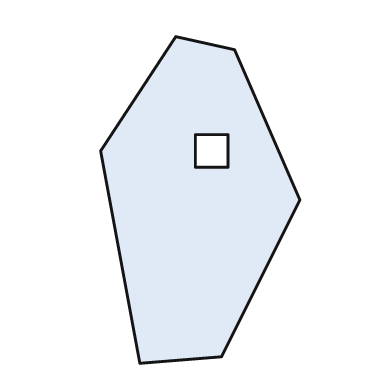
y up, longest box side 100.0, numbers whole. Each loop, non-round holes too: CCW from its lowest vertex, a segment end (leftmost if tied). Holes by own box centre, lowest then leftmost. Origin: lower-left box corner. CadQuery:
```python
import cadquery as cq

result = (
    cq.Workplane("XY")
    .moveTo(12.0, 0.0)
    .lineTo(37.0, 2.0)
    .lineTo(61.0, 50.0)
    .lineTo(41.0, 96.0)
    .lineTo(23.0, 100.0)
    .lineTo(0.0, 65.0)
    .close()
    .moveTo(29.0, 60.0)
    .lineTo(39.0, 60.0)
    .lineTo(39.0, 70.0)
    .lineTo(29.0, 70.0)
    .close()
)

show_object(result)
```